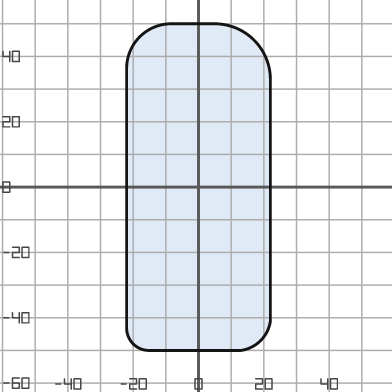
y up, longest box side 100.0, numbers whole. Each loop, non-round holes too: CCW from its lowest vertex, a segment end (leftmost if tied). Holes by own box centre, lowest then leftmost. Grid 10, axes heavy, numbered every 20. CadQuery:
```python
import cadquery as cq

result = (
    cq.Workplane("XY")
    .moveTo(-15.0, -50.0)
    .lineTo(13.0, -50.0)
    .threePointArc((19.0, -47.0), (22.0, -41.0))
    .lineTo(22.0, 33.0)
    .threePointArc((17.0, 45.0), (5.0, 50.0))
    .lineTo(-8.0, 50.0)
    .threePointArc((-18.0, 46.0), (-22.0, 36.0))
    .lineTo(-22.0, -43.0)
    .threePointArc((-20.0, -48.0), (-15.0, -50.0))
    .close()
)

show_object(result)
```